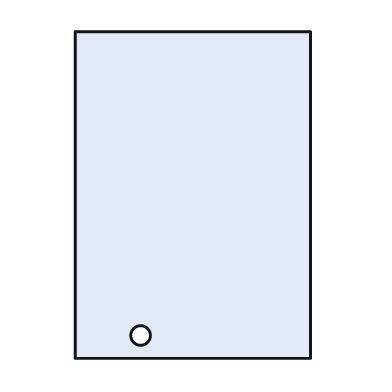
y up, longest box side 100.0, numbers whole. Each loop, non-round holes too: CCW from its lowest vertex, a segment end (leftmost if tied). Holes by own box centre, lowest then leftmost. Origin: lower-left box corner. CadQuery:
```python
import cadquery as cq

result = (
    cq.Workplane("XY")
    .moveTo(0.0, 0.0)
    .lineTo(72.0, 0.0)
    .lineTo(72.0, 100.0)
    .lineTo(0.0, 100.0)
    .close()
    .moveTo(20.0, 7.0)
    .circle(3.0)
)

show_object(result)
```